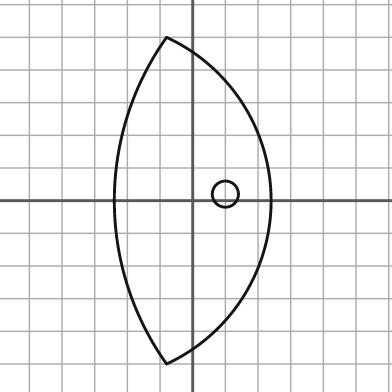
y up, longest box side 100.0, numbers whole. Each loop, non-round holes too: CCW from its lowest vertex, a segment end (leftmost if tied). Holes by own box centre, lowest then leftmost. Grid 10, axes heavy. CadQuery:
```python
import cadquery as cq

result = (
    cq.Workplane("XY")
    .moveTo(-8.0, -50.0)
    .threePointArc((24.0, 0.0), (-8.0, 50.0))
    .threePointArc((-24.0, 0.0), (-8.0, -50.0))
    .close()
    .moveTo(10.0, 2.0)
    .circle(4.0)
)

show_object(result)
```